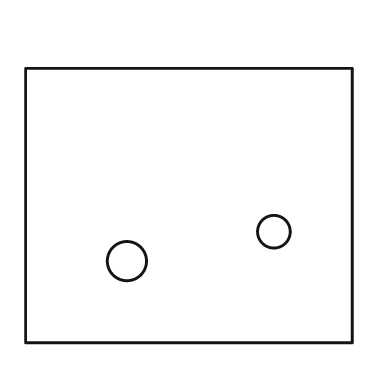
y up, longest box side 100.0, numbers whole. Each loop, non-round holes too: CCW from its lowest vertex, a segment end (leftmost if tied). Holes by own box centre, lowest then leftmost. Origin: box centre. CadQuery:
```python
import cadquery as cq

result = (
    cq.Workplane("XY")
    .moveTo(-50.0, -42.0)
    .lineTo(50.0, -42.0)
    .lineTo(50.0, 42.0)
    .lineTo(-50.0, 42.0)
    .close()
    .moveTo(-19.0, -17.0)
    .circle(6.0)
    .moveTo(26.0, -8.0)
    .circle(5.0)
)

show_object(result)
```